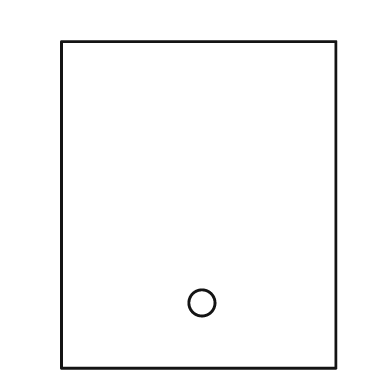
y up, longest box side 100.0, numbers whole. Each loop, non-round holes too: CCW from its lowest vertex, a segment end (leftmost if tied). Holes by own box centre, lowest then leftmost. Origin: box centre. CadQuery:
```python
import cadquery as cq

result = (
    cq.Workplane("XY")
    .moveTo(-42.0, -50.0)
    .lineTo(42.0, -50.0)
    .lineTo(42.0, 50.0)
    .lineTo(-42.0, 50.0)
    .close()
    .moveTo(1.0, -30.0)
    .circle(4.0)
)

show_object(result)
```